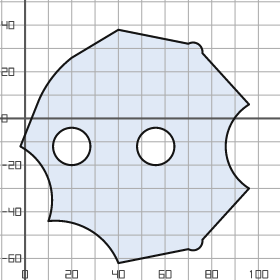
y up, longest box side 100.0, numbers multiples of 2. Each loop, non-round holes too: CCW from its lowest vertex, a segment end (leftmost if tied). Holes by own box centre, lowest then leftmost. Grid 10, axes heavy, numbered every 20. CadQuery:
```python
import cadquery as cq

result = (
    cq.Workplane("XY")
    .moveTo(40.0, -62.0)
    .lineTo(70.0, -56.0)
    .threePointArc((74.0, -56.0), (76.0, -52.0))
    .lineTo(96.0, -30.0)
    .threePointArc((86.0, -12.0), (96.0, 6.0))
    .lineTo(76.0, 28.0)
    .threePointArc((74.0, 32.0), (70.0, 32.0))
    .lineTo(40.0, 38.0)
    .lineTo(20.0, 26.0)
    .threePointArc((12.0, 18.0), (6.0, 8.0))
    .lineTo(-2.0, -12.0)
    .threePointArc((10.0, -26.0), (10.0, -44.0))
    .threePointArc((28.0, -48.0), (40.0, -62.0))
    .close()
    .moveTo(20.0, -12.0)
    .circle(8.0)
    .moveTo(56.0, -12.0)
    .circle(8.0)
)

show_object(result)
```